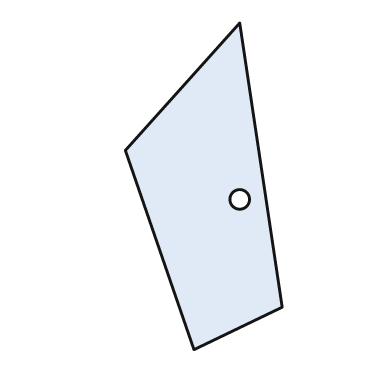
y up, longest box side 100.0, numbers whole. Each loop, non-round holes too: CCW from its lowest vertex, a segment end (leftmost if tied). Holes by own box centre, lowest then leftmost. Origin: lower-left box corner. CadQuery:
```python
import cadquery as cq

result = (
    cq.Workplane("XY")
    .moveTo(21.0, 0.0)
    .lineTo(48.0, 13.0)
    .lineTo(35.0, 100.0)
    .lineTo(0.0, 61.0)
    .close()
    .moveTo(35.0, 46.0)
    .circle(3.0)
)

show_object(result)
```